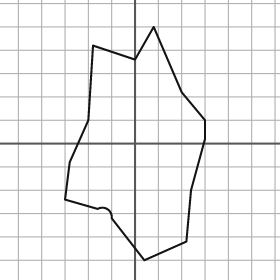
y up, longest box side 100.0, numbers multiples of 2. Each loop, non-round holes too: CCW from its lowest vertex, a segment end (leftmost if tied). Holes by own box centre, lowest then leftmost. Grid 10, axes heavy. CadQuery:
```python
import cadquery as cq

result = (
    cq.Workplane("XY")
    .moveTo(4.0, -50.0)
    .lineTo(22.0, -42.0)
    .lineTo(24.0, -20.0)
    .lineTo(30.0, 2.0)
    .lineTo(30.0, 10.0)
    .lineTo(20.0, 22.0)
    .lineTo(8.0, 50.0)
    .lineTo(0.0, 36.0)
    .lineTo(-18.0, 42.0)
    .lineTo(-20.0, 10.0)
    .lineTo(-28.0, -8.0)
    .lineTo(-30.0, -24.0)
    .lineTo(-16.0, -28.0)
    .threePointArc((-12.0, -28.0), (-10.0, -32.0))
    .close()
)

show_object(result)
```